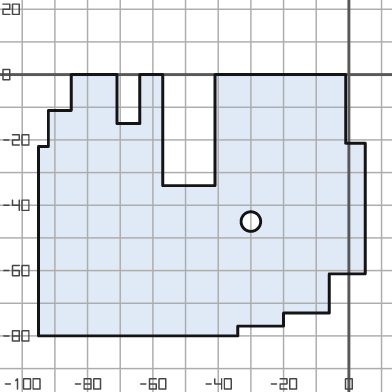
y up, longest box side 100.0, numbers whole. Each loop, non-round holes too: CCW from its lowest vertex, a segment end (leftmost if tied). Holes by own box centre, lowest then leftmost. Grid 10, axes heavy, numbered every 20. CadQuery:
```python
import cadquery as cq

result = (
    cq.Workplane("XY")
    .moveTo(-95.0, -80.0)
    .lineTo(-34.0, -80.0)
    .lineTo(-34.0, -77.0)
    .lineTo(-20.0, -77.0)
    .lineTo(-20.0, -73.0)
    .lineTo(-6.0, -73.0)
    .lineTo(-6.0, -61.0)
    .lineTo(5.0, -61.0)
    .lineTo(5.0, -21.0)
    .lineTo(-1.0, -21.0)
    .lineTo(-1.0, 0.0)
    .lineTo(-41.0, 0.0)
    .lineTo(-41.0, -34.0)
    .lineTo(-57.0, -34.0)
    .lineTo(-57.0, 0.0)
    .lineTo(-64.0, 0.0)
    .lineTo(-64.0, -15.0)
    .lineTo(-71.0, -15.0)
    .lineTo(-71.0, 0.0)
    .lineTo(-85.0, 0.0)
    .lineTo(-85.0, -11.0)
    .lineTo(-92.0, -11.0)
    .lineTo(-92.0, -22.0)
    .lineTo(-95.0, -22.0)
    .close()
    .moveTo(-30.0, -45.0)
    .circle(3.0)
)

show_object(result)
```